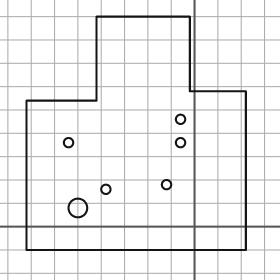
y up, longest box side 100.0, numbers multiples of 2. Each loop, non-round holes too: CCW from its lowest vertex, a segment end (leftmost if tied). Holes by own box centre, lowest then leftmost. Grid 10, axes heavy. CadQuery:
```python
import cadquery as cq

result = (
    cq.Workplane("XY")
    .moveTo(-72.0, -10.0)
    .lineTo(22.0, -10.0)
    .lineTo(22.0, 58.0)
    .lineTo(-2.0, 58.0)
    .lineTo(-2.0, 90.0)
    .lineTo(-42.0, 90.0)
    .lineTo(-42.0, 54.0)
    .lineTo(-72.0, 54.0)
    .close()
    .moveTo(-50.0, 8.0)
    .circle(4.0)
    .moveTo(-38.0, 16.0)
    .circle(2.0)
    .moveTo(-12.0, 18.0)
    .circle(2.0)
    .moveTo(-54.0, 36.0)
    .circle(2.0)
    .moveTo(-6.0, 36.0)
    .circle(2.0)
    .moveTo(-6.0, 46.0)
    .circle(2.0)
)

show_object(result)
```